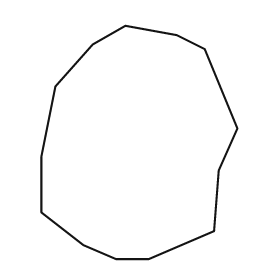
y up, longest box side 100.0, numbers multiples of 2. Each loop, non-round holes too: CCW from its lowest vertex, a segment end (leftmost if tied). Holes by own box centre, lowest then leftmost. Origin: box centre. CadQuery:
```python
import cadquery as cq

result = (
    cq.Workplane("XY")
    .moveTo(-10.0, -50.0)
    .lineTo(4.0, -50.0)
    .lineTo(32.0, -38.0)
    .lineTo(34.0, -12.0)
    .lineTo(42.0, 6.0)
    .lineTo(28.0, 40.0)
    .lineTo(16.0, 46.0)
    .lineTo(-6.0, 50.0)
    .lineTo(-20.0, 42.0)
    .lineTo(-36.0, 24.0)
    .lineTo(-42.0, -6.0)
    .lineTo(-42.0, -30.0)
    .lineTo(-24.0, -44.0)
    .close()
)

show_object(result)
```